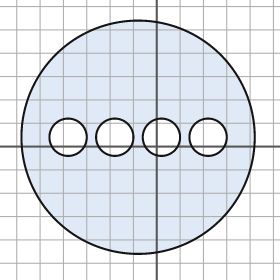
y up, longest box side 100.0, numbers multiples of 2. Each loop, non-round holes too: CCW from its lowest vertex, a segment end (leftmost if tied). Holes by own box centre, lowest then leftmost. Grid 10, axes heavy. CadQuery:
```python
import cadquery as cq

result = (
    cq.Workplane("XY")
    .moveTo(-8.0, 4.0)
    .circle(50.0)
    .moveTo(-38.0, 4.0)
    .circle(8.0)
    .moveTo(-18.0, 4.0)
    .circle(8.0)
    .moveTo(2.0, 4.0)
    .circle(8.0)
    .moveTo(22.0, 4.0)
    .circle(8.0)
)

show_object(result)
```